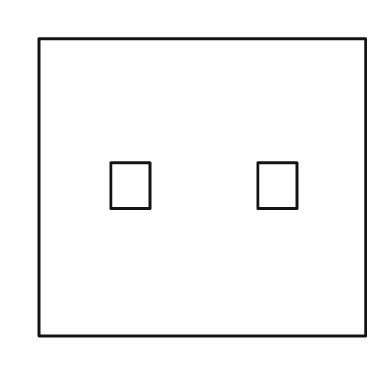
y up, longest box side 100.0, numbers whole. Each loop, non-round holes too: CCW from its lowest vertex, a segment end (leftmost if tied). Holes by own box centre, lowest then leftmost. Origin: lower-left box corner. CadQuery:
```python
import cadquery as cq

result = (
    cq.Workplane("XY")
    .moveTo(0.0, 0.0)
    .lineTo(100.0, 0.0)
    .lineTo(100.0, 91.0)
    .lineTo(0.0, 91.0)
    .close()
    .moveTo(22.0, 39.0)
    .lineTo(34.0, 39.0)
    .lineTo(34.0, 53.0)
    .lineTo(22.0, 53.0)
    .close()
    .moveTo(67.0, 39.0)
    .lineTo(79.0, 39.0)
    .lineTo(79.0, 53.0)
    .lineTo(67.0, 53.0)
    .close()
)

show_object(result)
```